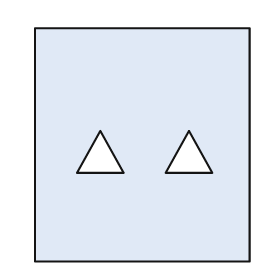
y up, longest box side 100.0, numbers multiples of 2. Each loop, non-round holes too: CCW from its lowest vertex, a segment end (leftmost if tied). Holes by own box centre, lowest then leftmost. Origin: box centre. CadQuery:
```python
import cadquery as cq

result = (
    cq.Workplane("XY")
    .moveTo(-46.0, -50.0)
    .lineTo(46.0, -50.0)
    .lineTo(46.0, 50.0)
    .lineTo(-46.0, 50.0)
    .close()
    .moveTo(-28.0, -12.0)
    .lineTo(-8.0, -12.0)
    .lineTo(-18.0, 6.0)
    .close()
    .moveTo(10.0, -12.0)
    .lineTo(30.0, -12.0)
    .lineTo(20.0, 6.0)
    .close()
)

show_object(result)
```